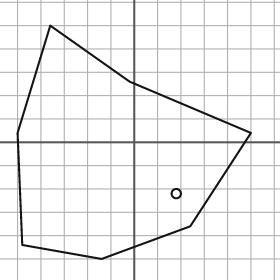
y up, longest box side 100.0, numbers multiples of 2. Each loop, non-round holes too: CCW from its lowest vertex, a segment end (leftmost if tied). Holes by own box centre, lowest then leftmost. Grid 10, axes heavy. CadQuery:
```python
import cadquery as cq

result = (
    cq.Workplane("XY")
    .moveTo(-14.0, -50.0)
    .lineTo(24.0, -36.0)
    .lineTo(50.0, 4.0)
    .lineTo(-2.0, 26.0)
    .lineTo(-36.0, 50.0)
    .lineTo(-50.0, 4.0)
    .lineTo(-48.0, -44.0)
    .close()
    .moveTo(18.0, -22.0)
    .circle(2.0)
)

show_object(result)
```